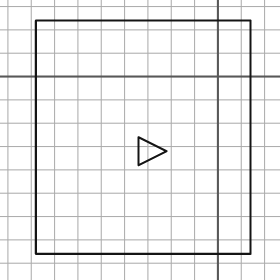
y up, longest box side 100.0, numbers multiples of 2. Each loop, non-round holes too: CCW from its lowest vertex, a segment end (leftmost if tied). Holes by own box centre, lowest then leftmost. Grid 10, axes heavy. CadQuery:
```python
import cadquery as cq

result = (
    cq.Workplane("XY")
    .moveTo(-78.0, -76.0)
    .lineTo(14.0, -76.0)
    .lineTo(14.0, 24.0)
    .lineTo(-78.0, 24.0)
    .close()
    .moveTo(-34.0, -38.0)
    .lineTo(-22.0, -32.0)
    .lineTo(-34.0, -26.0)
    .close()
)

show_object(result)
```